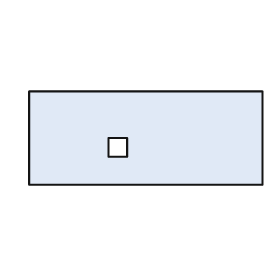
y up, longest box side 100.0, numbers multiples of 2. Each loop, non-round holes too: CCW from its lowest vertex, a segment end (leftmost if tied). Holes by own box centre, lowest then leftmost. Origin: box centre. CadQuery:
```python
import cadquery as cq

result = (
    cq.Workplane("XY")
    .moveTo(-50.0, -20.0)
    .lineTo(50.0, -20.0)
    .lineTo(50.0, 20.0)
    .lineTo(-50.0, 20.0)
    .close()
    .moveTo(-16.0, -8.0)
    .lineTo(-8.0, -8.0)
    .lineTo(-8.0, 0.0)
    .lineTo(-16.0, 0.0)
    .close()
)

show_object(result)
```